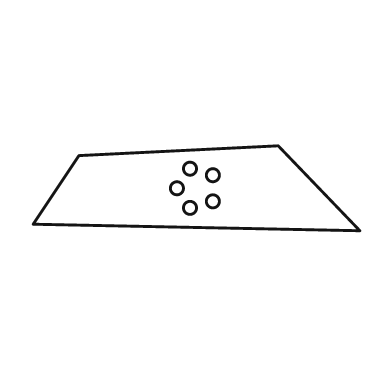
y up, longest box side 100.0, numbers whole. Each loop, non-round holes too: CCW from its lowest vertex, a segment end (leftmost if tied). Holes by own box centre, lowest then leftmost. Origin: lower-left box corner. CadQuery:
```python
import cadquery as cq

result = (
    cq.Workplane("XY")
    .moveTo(100.0, 0.0)
    .lineTo(75.0, 26.0)
    .lineTo(14.0, 23.0)
    .lineTo(0.0, 2.0)
    .close()
    .moveTo(48.0, 7.0)
    .circle(2.0)
    .moveTo(55.0, 9.0)
    .circle(2.0)
    .moveTo(44.0, 13.0)
    .circle(2.0)
    .moveTo(55.0, 17.0)
    .circle(2.0)
    .moveTo(48.0, 19.0)
    .circle(2.0)
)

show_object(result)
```